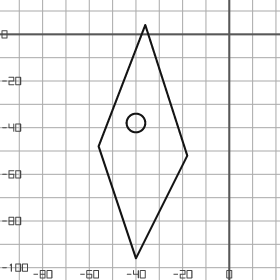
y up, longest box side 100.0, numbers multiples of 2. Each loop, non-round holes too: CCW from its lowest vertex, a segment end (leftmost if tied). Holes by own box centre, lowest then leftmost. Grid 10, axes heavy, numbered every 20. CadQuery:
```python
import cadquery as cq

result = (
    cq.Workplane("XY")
    .moveTo(-40.0, -96.0)
    .lineTo(-18.0, -52.0)
    .lineTo(-36.0, 4.0)
    .lineTo(-56.0, -48.0)
    .close()
    .moveTo(-40.0, -38.0)
    .circle(4.0)
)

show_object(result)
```